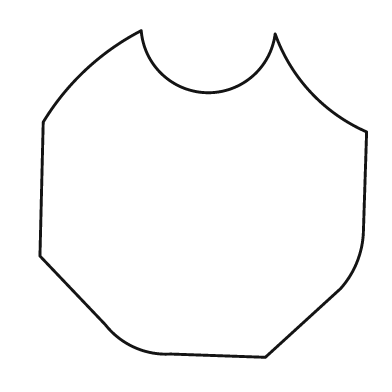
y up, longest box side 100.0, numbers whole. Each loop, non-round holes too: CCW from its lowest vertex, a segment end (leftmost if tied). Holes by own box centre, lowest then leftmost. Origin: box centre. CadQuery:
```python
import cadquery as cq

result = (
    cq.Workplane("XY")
    .moveTo(19.0, -50.0)
    .lineTo(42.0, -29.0)
    .threePointArc((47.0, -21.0), (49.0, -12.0))
    .lineTo(50.0, 19.0)
    .threePointArc((33.0, 31.0), (22.0, 49.0))
    .threePointArc((1.0, 31.0), (-19.0, 50.0))
    .threePointArc((-36.0, 38.0), (-49.0, 22.0))
    .lineTo(-50.0, -19.0)
    .lineTo(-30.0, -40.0)
    .threePointArc((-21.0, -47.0), (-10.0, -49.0))
    .close()
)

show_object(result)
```